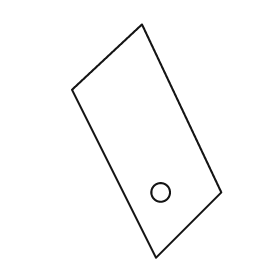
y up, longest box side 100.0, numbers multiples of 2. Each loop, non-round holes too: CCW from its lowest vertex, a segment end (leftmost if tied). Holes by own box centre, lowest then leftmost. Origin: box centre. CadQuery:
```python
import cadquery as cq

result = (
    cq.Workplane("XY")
    .moveTo(4.0, -50.0)
    .lineTo(32.0, -22.0)
    .lineTo(-2.0, 50.0)
    .lineTo(-32.0, 22.0)
    .close()
    .moveTo(6.0, -22.0)
    .circle(4.0)
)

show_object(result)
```